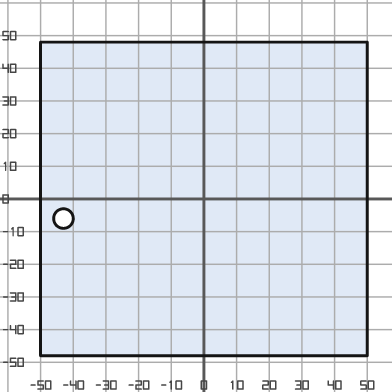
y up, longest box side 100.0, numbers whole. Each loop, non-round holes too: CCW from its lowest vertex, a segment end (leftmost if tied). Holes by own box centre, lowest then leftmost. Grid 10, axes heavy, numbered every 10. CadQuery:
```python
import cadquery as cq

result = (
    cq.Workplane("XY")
    .moveTo(-50.0, -48.0)
    .lineTo(50.0, -48.0)
    .lineTo(50.0, 48.0)
    .lineTo(-50.0, 48.0)
    .close()
    .moveTo(-43.0, -6.0)
    .circle(3.0)
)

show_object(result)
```